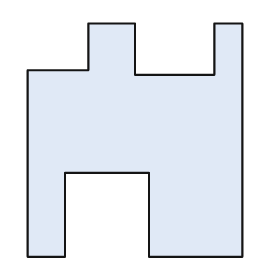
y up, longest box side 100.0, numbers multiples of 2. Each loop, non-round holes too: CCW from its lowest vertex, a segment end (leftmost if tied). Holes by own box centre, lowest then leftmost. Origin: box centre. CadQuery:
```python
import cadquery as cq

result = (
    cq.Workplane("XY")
    .moveTo(-46.0, -50.0)
    .lineTo(-30.0, -50.0)
    .lineTo(-30.0, -14.0)
    .lineTo(6.0, -14.0)
    .lineTo(6.0, -50.0)
    .lineTo(46.0, -50.0)
    .lineTo(46.0, 50.0)
    .lineTo(34.0, 50.0)
    .lineTo(34.0, 28.0)
    .lineTo(0.0, 28.0)
    .lineTo(0.0, 50.0)
    .lineTo(-20.0, 50.0)
    .lineTo(-20.0, 30.0)
    .lineTo(-46.0, 30.0)
    .close()
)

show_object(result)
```